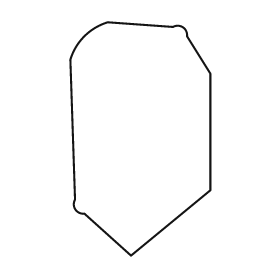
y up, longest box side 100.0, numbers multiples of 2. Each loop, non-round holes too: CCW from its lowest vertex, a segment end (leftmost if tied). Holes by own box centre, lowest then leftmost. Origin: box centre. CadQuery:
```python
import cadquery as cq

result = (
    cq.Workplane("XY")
    .moveTo(-4.0, -50.0)
    .lineTo(30.0, -22.0)
    .lineTo(30.0, 28.0)
    .lineTo(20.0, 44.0)
    .threePointArc((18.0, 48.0), (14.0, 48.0))
    .lineTo(-14.0, 50.0)
    .threePointArc((-24.0, 44.0), (-30.0, 34.0))
    .lineTo(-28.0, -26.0)
    .threePointArc((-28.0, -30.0), (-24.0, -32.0))
    .close()
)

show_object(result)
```